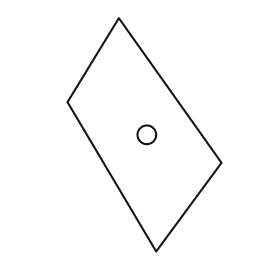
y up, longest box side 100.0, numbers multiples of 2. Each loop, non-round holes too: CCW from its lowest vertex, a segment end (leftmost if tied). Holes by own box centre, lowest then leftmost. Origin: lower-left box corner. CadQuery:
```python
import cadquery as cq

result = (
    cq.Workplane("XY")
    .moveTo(38.0, 0.0)
    .lineTo(66.0, 38.0)
    .lineTo(22.0, 100.0)
    .lineTo(0.0, 64.0)
    .close()
    .moveTo(34.0, 50.0)
    .circle(4.0)
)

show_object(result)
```